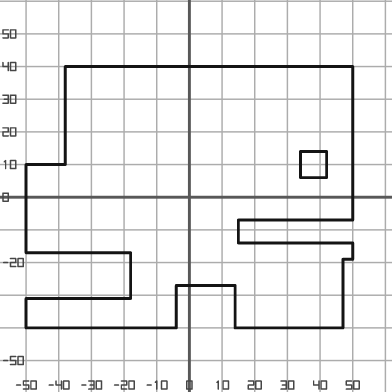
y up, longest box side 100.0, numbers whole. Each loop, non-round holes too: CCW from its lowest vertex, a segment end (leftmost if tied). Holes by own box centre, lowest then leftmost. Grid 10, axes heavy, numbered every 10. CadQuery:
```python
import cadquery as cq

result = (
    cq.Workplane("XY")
    .moveTo(-50.0, -40.0)
    .lineTo(-4.0, -40.0)
    .lineTo(-4.0, -27.0)
    .lineTo(14.0, -27.0)
    .lineTo(14.0, -40.0)
    .lineTo(47.0, -40.0)
    .lineTo(47.0, -19.0)
    .lineTo(50.0, -19.0)
    .lineTo(50.0, -14.0)
    .lineTo(15.0, -14.0)
    .lineTo(15.0, -7.0)
    .lineTo(50.0, -7.0)
    .lineTo(50.0, 40.0)
    .lineTo(-38.0, 40.0)
    .lineTo(-38.0, 10.0)
    .lineTo(-50.0, 10.0)
    .lineTo(-50.0, -17.0)
    .lineTo(-18.0, -17.0)
    .lineTo(-18.0, -31.0)
    .lineTo(-50.0, -31.0)
    .close()
    .moveTo(34.0, 6.0)
    .lineTo(42.0, 6.0)
    .lineTo(42.0, 14.0)
    .lineTo(34.0, 14.0)
    .close()
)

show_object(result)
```